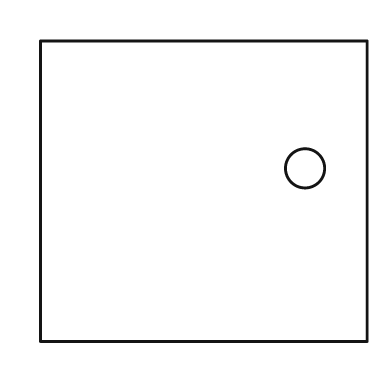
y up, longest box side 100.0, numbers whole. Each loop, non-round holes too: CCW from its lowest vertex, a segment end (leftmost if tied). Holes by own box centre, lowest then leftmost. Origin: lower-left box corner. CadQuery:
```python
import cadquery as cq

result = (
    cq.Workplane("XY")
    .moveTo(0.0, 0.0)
    .lineTo(100.0, 0.0)
    .lineTo(100.0, 92.0)
    .lineTo(0.0, 92.0)
    .close()
    .moveTo(81.0, 53.0)
    .circle(6.0)
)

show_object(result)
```